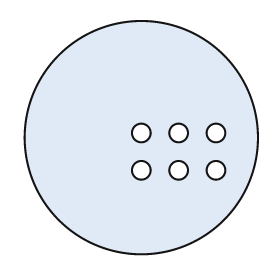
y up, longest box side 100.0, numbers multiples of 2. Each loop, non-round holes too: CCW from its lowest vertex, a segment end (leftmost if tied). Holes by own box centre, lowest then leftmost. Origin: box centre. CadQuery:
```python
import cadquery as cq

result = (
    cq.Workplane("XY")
    .moveTo(0.0, 0.0)
    .circle(50.0)
    .moveTo(0.0, -14.0)
    .circle(4.0)
    .moveTo(16.0, -14.0)
    .circle(4.0)
    .moveTo(32.0, -14.0)
    .circle(4.0)
    .moveTo(0.0, 2.0)
    .circle(4.0)
    .moveTo(16.0, 2.0)
    .circle(4.0)
    .moveTo(32.0, 2.0)
    .circle(4.0)
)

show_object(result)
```